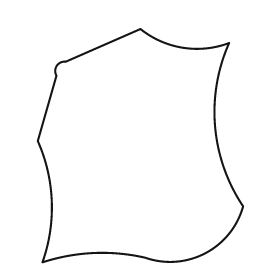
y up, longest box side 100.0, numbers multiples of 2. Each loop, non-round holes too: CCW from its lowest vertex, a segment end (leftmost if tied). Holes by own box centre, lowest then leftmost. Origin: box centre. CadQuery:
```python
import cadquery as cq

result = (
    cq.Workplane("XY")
    .moveTo(-42.0, -50.0)
    .threePointArc((-20.0, -46.0), (2.0, -48.0))
    .threePointArc((28.0, -46.0), (44.0, -26.0))
    .threePointArc((32.0, 8.0), (38.0, 44.0))
    .threePointArc((18.0, 42.0), (0.0, 50.0))
    .lineTo(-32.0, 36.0)
    .threePointArc((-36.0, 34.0), (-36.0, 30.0))
    .lineTo(-44.0, 2.0)
    .threePointArc((-38.0, -24.0), (-42.0, -50.0))
    .close()
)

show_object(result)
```